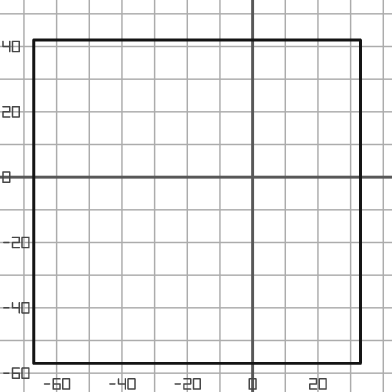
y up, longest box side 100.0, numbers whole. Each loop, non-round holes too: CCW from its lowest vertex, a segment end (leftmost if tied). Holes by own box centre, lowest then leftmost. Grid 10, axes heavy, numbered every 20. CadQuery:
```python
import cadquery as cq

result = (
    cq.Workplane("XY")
    .moveTo(-67.0, -57.0)
    .lineTo(33.0, -57.0)
    .lineTo(33.0, 42.0)
    .lineTo(-67.0, 42.0)
    .close()
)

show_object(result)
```